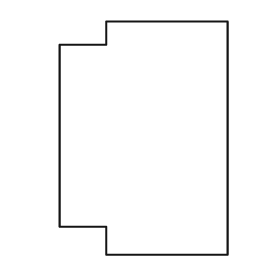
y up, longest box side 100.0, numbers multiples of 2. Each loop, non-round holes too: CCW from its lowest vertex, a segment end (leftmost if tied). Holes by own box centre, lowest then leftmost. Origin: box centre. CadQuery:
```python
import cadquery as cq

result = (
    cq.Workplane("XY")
    .moveTo(-16.0, -50.0)
    .lineTo(36.0, -50.0)
    .lineTo(36.0, 50.0)
    .lineTo(-16.0, 50.0)
    .lineTo(-16.0, 40.0)
    .lineTo(-36.0, 40.0)
    .lineTo(-36.0, -38.0)
    .lineTo(-16.0, -38.0)
    .close()
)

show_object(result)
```